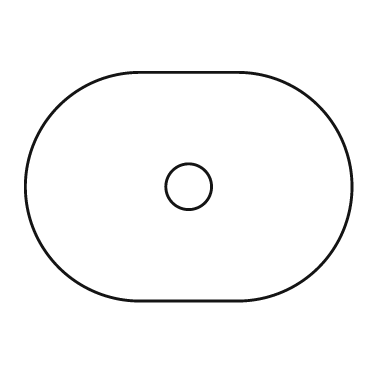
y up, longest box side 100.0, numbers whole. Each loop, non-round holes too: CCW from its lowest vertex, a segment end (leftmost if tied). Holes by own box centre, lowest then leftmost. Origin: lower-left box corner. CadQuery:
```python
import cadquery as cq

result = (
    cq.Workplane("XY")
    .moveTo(35.0, 0.0)
    .lineTo(65.0, 0.0)
    .threePointArc((100.0, 35.0), (65.0, 70.0))
    .lineTo(35.0, 70.0)
    .threePointArc((0.0, 35.0), (35.0, 0.0))
    .close()
    .moveTo(50.0, 35.0)
    .circle(7.0)
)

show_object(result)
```